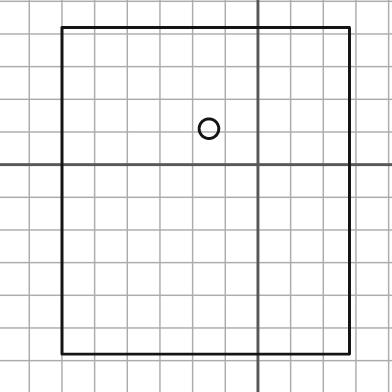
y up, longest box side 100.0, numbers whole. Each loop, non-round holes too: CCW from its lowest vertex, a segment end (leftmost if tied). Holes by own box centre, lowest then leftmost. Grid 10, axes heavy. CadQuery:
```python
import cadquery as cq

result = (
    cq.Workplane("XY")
    .moveTo(-60.0, -58.0)
    .lineTo(28.0, -58.0)
    .lineTo(28.0, 42.0)
    .lineTo(-60.0, 42.0)
    .close()
    .moveTo(-15.0, 11.0)
    .circle(3.0)
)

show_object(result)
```